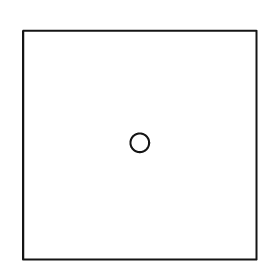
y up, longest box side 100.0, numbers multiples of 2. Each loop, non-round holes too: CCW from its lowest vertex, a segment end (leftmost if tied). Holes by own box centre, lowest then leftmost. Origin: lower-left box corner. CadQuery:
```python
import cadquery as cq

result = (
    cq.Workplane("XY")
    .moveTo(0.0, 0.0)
    .lineTo(100.0, 0.0)
    .lineTo(100.0, 98.0)
    .lineTo(0.0, 98.0)
    .close()
    .moveTo(50.0, 50.0)
    .circle(4.0)
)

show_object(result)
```